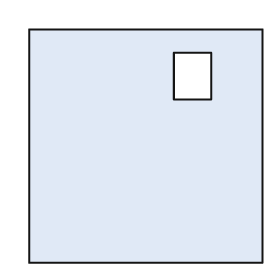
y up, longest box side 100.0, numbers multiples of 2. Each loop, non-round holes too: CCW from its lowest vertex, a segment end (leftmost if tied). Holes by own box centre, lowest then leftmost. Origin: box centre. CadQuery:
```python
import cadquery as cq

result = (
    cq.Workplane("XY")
    .moveTo(-50.0, -50.0)
    .lineTo(50.0, -50.0)
    .lineTo(50.0, 50.0)
    .lineTo(-50.0, 50.0)
    .close()
    .moveTo(12.0, 20.0)
    .lineTo(28.0, 20.0)
    .lineTo(28.0, 40.0)
    .lineTo(12.0, 40.0)
    .close()
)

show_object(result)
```